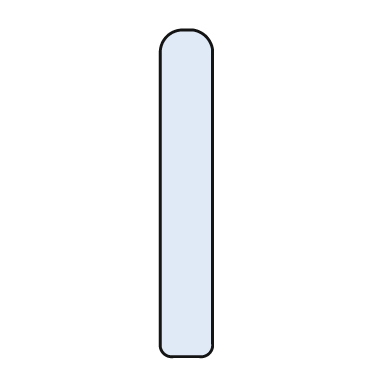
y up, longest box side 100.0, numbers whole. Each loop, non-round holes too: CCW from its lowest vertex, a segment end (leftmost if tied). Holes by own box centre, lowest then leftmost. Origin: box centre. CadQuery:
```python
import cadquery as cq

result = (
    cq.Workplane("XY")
    .moveTo(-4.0, -50.0)
    .lineTo(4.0, -50.0)
    .threePointArc((7.0, -49.0), (8.0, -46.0))
    .lineTo(8.0, 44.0)
    .threePointArc((6.0, 48.0), (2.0, 50.0))
    .lineTo(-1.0, 50.0)
    .threePointArc((-6.0, 48.0), (-8.0, 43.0))
    .lineTo(-8.0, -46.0)
    .threePointArc((-7.0, -49.0), (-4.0, -50.0))
    .close()
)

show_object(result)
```